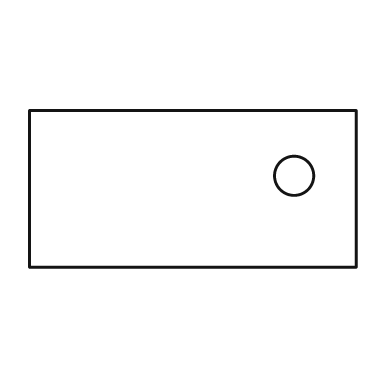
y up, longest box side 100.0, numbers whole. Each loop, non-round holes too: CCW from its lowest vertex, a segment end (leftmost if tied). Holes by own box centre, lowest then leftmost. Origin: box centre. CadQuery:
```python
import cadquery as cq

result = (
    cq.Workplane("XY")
    .moveTo(-50.0, -24.0)
    .lineTo(50.0, -24.0)
    .lineTo(50.0, 24.0)
    .lineTo(-50.0, 24.0)
    .close()
    .moveTo(31.0, 4.0)
    .circle(6.0)
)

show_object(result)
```